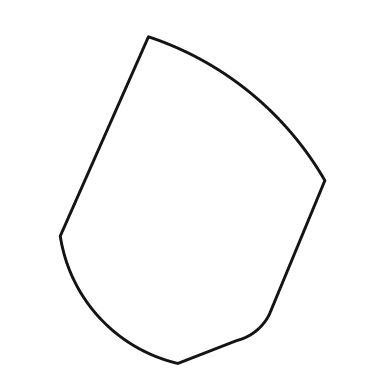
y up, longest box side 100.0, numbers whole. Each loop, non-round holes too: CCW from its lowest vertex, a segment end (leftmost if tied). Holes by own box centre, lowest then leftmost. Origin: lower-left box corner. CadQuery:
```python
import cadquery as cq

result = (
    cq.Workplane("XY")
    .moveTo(36.0, 0.0)
    .lineTo(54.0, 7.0)
    .threePointArc((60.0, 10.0), (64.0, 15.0))
    .lineTo(81.0, 56.0)
    .threePointArc((58.0, 83.0), (27.0, 100.0))
    .lineTo(0.0, 39.0)
    .threePointArc((12.0, 14.0), (36.0, 0.0))
    .close()
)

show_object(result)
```